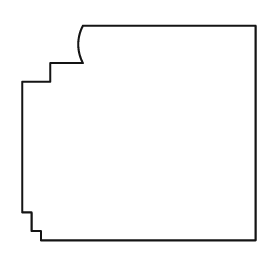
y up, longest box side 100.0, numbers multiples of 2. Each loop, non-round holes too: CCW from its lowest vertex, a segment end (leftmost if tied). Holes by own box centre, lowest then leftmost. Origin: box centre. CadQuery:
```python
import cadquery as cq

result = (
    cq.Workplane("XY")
    .moveTo(-42.0, -46.0)
    .lineTo(50.0, -46.0)
    .lineTo(50.0, 46.0)
    .lineTo(-24.0, 46.0)
    .threePointArc((-26.0, 38.0), (-24.0, 30.0))
    .lineTo(-38.0, 30.0)
    .lineTo(-38.0, 22.0)
    .lineTo(-50.0, 22.0)
    .lineTo(-50.0, -34.0)
    .lineTo(-46.0, -34.0)
    .lineTo(-46.0, -42.0)
    .lineTo(-42.0, -42.0)
    .close()
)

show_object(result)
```